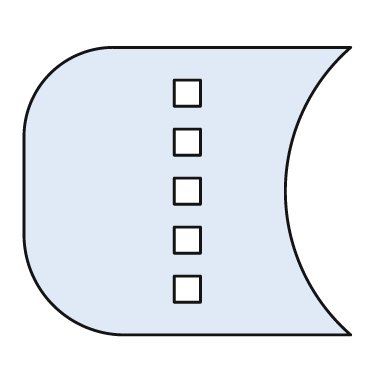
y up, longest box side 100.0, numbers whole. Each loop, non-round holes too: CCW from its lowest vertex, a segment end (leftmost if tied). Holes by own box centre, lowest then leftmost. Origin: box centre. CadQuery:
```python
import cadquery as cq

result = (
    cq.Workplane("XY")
    .moveTo(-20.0, -44.0)
    .lineTo(50.0, -44.0)
    .threePointArc((30.0, 0.0), (50.0, 44.0))
    .lineTo(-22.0, 44.0)
    .threePointArc((-42.0, 36.0), (-50.0, 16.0))
    .lineTo(-50.0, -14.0)
    .threePointArc((-41.0, -35.0), (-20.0, -44.0))
    .close()
    .moveTo(-4.0, -34.0)
    .lineTo(4.0, -34.0)
    .lineTo(4.0, -26.0)
    .lineTo(-4.0, -26.0)
    .close()
    .moveTo(-4.0, -19.0)
    .lineTo(4.0, -19.0)
    .lineTo(4.0, -11.0)
    .lineTo(-4.0, -11.0)
    .close()
    .moveTo(-4.0, -4.0)
    .lineTo(4.0, -4.0)
    .lineTo(4.0, 4.0)
    .lineTo(-4.0, 4.0)
    .close()
    .moveTo(-4.0, 11.0)
    .lineTo(4.0, 11.0)
    .lineTo(4.0, 19.0)
    .lineTo(-4.0, 19.0)
    .close()
    .moveTo(-4.0, 26.0)
    .lineTo(4.0, 26.0)
    .lineTo(4.0, 34.0)
    .lineTo(-4.0, 34.0)
    .close()
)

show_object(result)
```